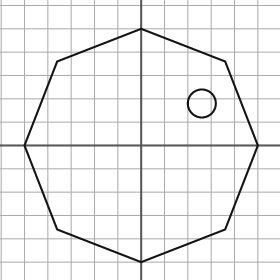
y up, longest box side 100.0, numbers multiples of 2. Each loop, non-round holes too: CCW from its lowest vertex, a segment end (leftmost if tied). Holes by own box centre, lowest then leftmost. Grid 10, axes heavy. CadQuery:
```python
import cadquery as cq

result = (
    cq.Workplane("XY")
    .moveTo(0.0, -50.0)
    .lineTo(36.0, -36.0)
    .lineTo(50.0, 0.0)
    .lineTo(36.0, 36.0)
    .lineTo(0.0, 50.0)
    .lineTo(-36.0, 36.0)
    .lineTo(-50.0, 0.0)
    .lineTo(-36.0, -36.0)
    .close()
    .moveTo(26.0, 18.0)
    .circle(6.0)
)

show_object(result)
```